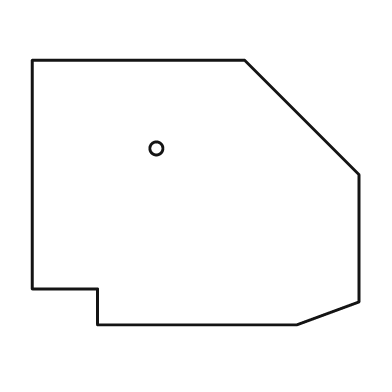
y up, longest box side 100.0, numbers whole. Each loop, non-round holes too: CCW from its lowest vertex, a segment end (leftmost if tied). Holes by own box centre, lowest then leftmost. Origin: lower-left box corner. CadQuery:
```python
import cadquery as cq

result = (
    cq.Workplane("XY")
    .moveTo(20.0, 0.0)
    .lineTo(81.0, 0.0)
    .lineTo(100.0, 7.0)
    .lineTo(100.0, 46.0)
    .lineTo(65.0, 81.0)
    .lineTo(0.0, 81.0)
    .lineTo(0.0, 11.0)
    .lineTo(20.0, 11.0)
    .close()
    .moveTo(38.0, 54.0)
    .circle(2.0)
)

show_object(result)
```